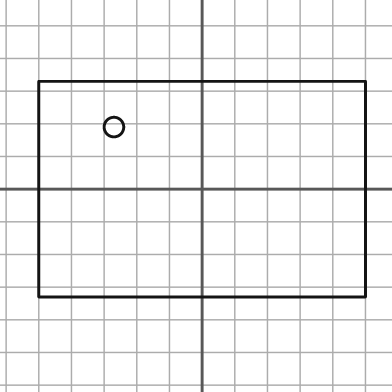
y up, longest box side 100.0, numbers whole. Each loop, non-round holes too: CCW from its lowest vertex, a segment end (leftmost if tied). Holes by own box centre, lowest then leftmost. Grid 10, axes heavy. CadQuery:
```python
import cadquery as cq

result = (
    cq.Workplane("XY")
    .moveTo(-50.0, -33.0)
    .lineTo(50.0, -33.0)
    .lineTo(50.0, 33.0)
    .lineTo(-50.0, 33.0)
    .close()
    .moveTo(-27.0, 19.0)
    .circle(3.0)
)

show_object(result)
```